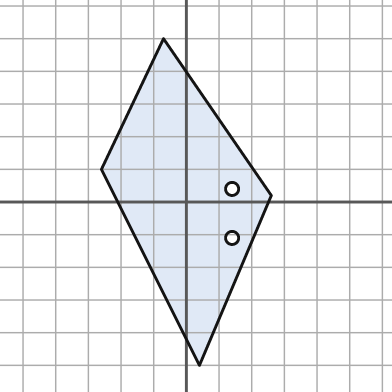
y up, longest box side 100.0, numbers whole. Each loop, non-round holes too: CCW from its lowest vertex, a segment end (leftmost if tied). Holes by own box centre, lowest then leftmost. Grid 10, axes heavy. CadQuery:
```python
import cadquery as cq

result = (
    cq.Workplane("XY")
    .moveTo(4.0, -50.0)
    .lineTo(26.0, 2.0)
    .lineTo(-7.0, 50.0)
    .lineTo(-26.0, 10.0)
    .close()
    .moveTo(14.0, -11.0)
    .circle(2.0)
    .moveTo(14.0, 4.0)
    .circle(2.0)
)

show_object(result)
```